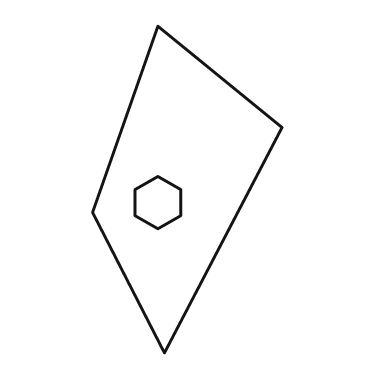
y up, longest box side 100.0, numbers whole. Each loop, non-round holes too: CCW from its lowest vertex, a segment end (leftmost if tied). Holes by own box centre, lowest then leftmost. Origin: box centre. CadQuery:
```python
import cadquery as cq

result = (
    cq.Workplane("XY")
    .moveTo(-7.0, -50.0)
    .lineTo(29.0, 19.0)
    .lineTo(-9.0, 50.0)
    .lineTo(-29.0, -7.0)
    .close()
    .moveTo(-9.0, -12.0)
    .lineTo(-2.0, -8.0)
    .lineTo(-2.0, 0.0)
    .lineTo(-9.0, 4.0)
    .lineTo(-16.0, 0.0)
    .lineTo(-16.0, -8.0)
    .close()
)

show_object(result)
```